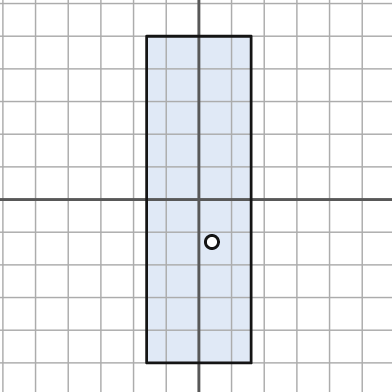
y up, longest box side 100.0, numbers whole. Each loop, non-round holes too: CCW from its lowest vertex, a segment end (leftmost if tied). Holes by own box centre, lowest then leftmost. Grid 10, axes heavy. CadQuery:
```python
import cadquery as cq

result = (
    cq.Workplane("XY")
    .moveTo(-16.0, -50.0)
    .lineTo(16.0, -50.0)
    .lineTo(16.0, 50.0)
    .lineTo(-16.0, 50.0)
    .close()
    .moveTo(4.0, -13.0)
    .circle(2.0)
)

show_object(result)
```